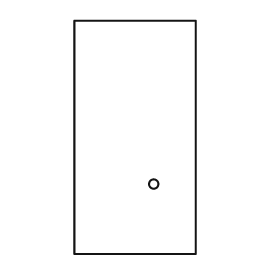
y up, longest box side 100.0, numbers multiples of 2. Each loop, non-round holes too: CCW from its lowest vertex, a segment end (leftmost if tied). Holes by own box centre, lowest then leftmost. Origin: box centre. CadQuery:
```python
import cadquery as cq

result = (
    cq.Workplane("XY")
    .moveTo(-26.0, -50.0)
    .lineTo(26.0, -50.0)
    .lineTo(26.0, 50.0)
    .lineTo(-26.0, 50.0)
    .close()
    .moveTo(8.0, -20.0)
    .circle(2.0)
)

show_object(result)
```